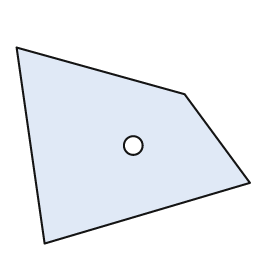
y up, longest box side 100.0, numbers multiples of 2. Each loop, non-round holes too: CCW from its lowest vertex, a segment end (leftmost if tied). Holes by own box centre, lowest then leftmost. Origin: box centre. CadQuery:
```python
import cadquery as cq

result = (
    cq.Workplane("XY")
    .moveTo(-38.0, -42.0)
    .lineTo(50.0, -16.0)
    .lineTo(22.0, 22.0)
    .lineTo(-50.0, 42.0)
    .close()
    .moveTo(0.0, 0.0)
    .circle(4.0)
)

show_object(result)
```